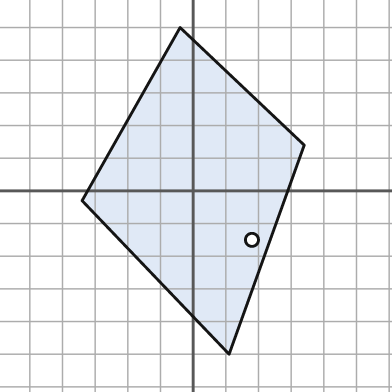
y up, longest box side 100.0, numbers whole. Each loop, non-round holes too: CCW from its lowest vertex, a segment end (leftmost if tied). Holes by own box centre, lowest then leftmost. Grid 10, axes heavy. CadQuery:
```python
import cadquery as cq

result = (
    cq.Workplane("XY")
    .moveTo(11.0, -50.0)
    .lineTo(34.0, 14.0)
    .lineTo(-4.0, 50.0)
    .lineTo(-34.0, -3.0)
    .close()
    .moveTo(18.0, -15.0)
    .circle(2.0)
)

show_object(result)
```